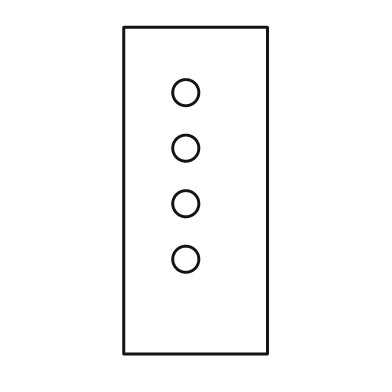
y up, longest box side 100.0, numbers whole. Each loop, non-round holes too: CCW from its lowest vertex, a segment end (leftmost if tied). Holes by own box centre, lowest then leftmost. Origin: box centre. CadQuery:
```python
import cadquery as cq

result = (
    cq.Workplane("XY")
    .moveTo(-22.0, -50.0)
    .lineTo(22.0, -50.0)
    .lineTo(22.0, 50.0)
    .lineTo(-22.0, 50.0)
    .close()
    .moveTo(-3.0, -21.0)
    .circle(4.0)
    .moveTo(-3.0, -4.0)
    .circle(4.0)
    .moveTo(-3.0, 13.0)
    .circle(4.0)
    .moveTo(-3.0, 30.0)
    .circle(4.0)
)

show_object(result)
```